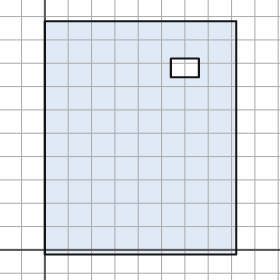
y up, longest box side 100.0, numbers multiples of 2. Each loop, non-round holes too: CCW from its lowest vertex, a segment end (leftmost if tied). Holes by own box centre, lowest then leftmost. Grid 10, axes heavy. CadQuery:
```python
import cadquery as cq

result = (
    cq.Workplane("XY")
    .moveTo(0.0, -2.0)
    .lineTo(82.0, -2.0)
    .lineTo(82.0, 98.0)
    .lineTo(0.0, 98.0)
    .close()
    .moveTo(54.0, 74.0)
    .lineTo(66.0, 74.0)
    .lineTo(66.0, 82.0)
    .lineTo(54.0, 82.0)
    .close()
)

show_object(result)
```